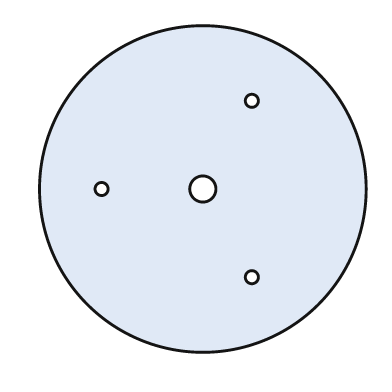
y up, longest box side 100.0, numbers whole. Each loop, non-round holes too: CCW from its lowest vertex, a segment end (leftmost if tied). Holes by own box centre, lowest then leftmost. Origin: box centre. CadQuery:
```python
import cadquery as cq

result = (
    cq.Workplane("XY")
    .moveTo(0.0, 0.0)
    .circle(50.0)
    .moveTo(15.0, -27.0)
    .circle(2.0)
    .moveTo(-31.0, 0.0)
    .circle(2.0)
    .moveTo(0.0, 0.0)
    .circle(4.0)
    .moveTo(15.0, 27.0)
    .circle(2.0)
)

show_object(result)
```